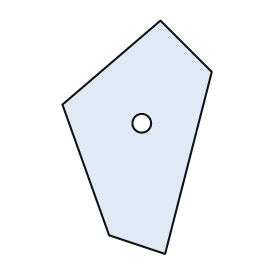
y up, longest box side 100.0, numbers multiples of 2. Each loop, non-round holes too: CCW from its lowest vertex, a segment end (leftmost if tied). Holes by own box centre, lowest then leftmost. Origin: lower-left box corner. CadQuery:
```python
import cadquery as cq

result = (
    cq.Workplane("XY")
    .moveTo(44.0, 0.0)
    .lineTo(64.0, 78.0)
    .lineTo(42.0, 100.0)
    .lineTo(0.0, 64.0)
    .lineTo(20.0, 8.0)
    .close()
    .moveTo(34.0, 56.0)
    .circle(4.0)
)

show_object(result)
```